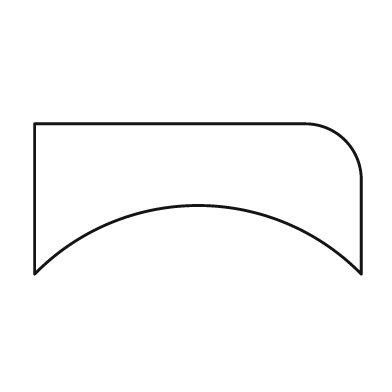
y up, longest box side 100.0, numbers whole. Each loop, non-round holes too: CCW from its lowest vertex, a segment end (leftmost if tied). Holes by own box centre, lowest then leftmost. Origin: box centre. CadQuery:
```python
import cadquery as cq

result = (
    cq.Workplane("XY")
    .moveTo(-50.0, -23.0)
    .threePointArc((0.0, -2.0), (50.0, -23.0))
    .lineTo(50.0, 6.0)
    .threePointArc((45.0, 18.0), (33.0, 23.0))
    .lineTo(-50.0, 23.0)
    .close()
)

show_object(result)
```